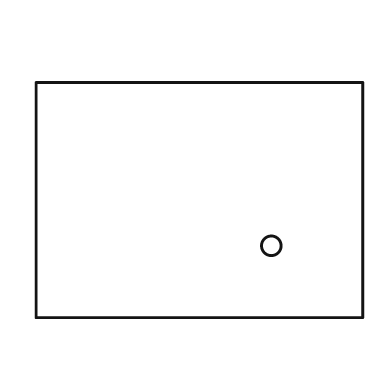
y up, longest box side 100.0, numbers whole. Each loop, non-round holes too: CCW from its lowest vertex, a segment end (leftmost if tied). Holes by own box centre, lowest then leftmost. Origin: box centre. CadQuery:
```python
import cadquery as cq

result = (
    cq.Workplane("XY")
    .moveTo(-50.0, -36.0)
    .lineTo(50.0, -36.0)
    .lineTo(50.0, 36.0)
    .lineTo(-50.0, 36.0)
    .close()
    .moveTo(22.0, -14.0)
    .circle(3.0)
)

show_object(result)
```